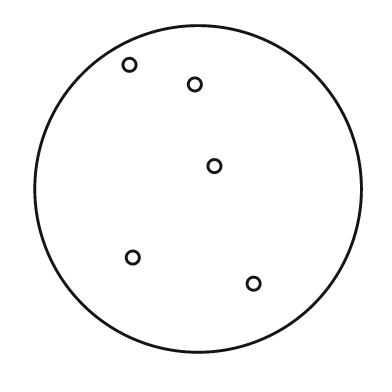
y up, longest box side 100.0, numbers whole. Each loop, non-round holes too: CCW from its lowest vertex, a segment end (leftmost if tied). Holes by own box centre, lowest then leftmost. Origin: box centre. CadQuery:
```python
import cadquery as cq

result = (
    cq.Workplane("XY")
    .moveTo(0.0, 0.0)
    .circle(50.0)
    .moveTo(17.0, -29.0)
    .circle(2.0)
    .moveTo(-20.0, -21.0)
    .circle(2.0)
    .moveTo(5.0, 7.0)
    .circle(2.0)
    .moveTo(-1.0, 32.0)
    .circle(2.0)
    .moveTo(-21.0, 38.0)
    .circle(2.0)
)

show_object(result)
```